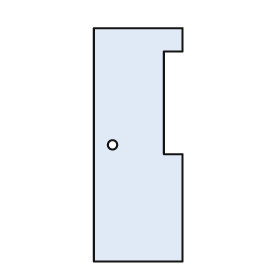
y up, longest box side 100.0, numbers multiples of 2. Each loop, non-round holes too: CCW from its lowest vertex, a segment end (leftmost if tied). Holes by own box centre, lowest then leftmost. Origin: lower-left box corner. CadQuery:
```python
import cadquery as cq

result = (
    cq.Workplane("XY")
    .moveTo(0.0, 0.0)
    .lineTo(38.0, 0.0)
    .lineTo(38.0, 46.0)
    .lineTo(30.0, 46.0)
    .lineTo(30.0, 90.0)
    .lineTo(38.0, 90.0)
    .lineTo(38.0, 100.0)
    .lineTo(0.0, 100.0)
    .close()
    .moveTo(8.0, 50.0)
    .circle(2.0)
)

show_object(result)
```